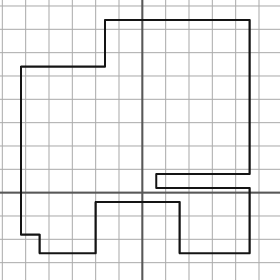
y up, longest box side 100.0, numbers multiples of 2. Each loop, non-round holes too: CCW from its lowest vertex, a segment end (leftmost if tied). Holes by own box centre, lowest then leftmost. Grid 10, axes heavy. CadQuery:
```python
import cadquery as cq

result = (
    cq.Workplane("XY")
    .moveTo(-44.0, -26.0)
    .lineTo(-20.0, -26.0)
    .lineTo(-20.0, -4.0)
    .lineTo(16.0, -4.0)
    .lineTo(16.0, -26.0)
    .lineTo(46.0, -26.0)
    .lineTo(46.0, 2.0)
    .lineTo(6.0, 2.0)
    .lineTo(6.0, 8.0)
    .lineTo(46.0, 8.0)
    .lineTo(46.0, 74.0)
    .lineTo(-16.0, 74.0)
    .lineTo(-16.0, 54.0)
    .lineTo(-52.0, 54.0)
    .lineTo(-52.0, -18.0)
    .lineTo(-44.0, -18.0)
    .close()
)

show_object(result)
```